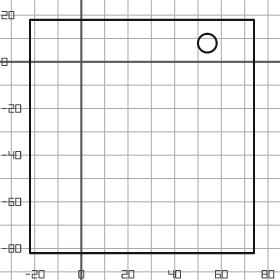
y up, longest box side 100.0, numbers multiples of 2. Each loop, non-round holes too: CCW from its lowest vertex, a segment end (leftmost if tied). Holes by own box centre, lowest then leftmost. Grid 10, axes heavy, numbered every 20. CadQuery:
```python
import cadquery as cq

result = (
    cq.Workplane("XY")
    .moveTo(-22.0, -82.0)
    .lineTo(74.0, -82.0)
    .lineTo(74.0, 18.0)
    .lineTo(-22.0, 18.0)
    .close()
    .moveTo(54.0, 8.0)
    .circle(4.0)
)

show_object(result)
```